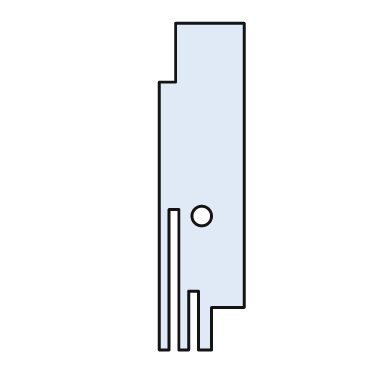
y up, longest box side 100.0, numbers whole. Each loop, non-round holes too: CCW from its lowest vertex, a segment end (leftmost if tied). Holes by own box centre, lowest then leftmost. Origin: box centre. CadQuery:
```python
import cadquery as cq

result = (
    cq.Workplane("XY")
    .moveTo(-13.0, -50.0)
    .lineTo(-10.0, -50.0)
    .lineTo(-10.0, -7.0)
    .lineTo(-7.0, -7.0)
    .lineTo(-7.0, -50.0)
    .lineTo(-4.0, -50.0)
    .lineTo(-4.0, -32.0)
    .lineTo(-1.0, -32.0)
    .lineTo(-1.0, -50.0)
    .lineTo(3.0, -50.0)
    .lineTo(3.0, -37.0)
    .lineTo(13.0, -37.0)
    .lineTo(13.0, 50.0)
    .lineTo(-8.0, 50.0)
    .lineTo(-8.0, 32.0)
    .lineTo(-13.0, 32.0)
    .close()
    .moveTo(0.0, -9.0)
    .circle(3.0)
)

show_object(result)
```